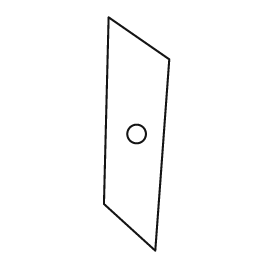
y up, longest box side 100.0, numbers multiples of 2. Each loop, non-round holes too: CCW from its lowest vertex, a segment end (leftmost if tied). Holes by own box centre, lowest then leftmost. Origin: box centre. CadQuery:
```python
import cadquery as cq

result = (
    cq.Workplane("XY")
    .moveTo(8.0, -50.0)
    .lineTo(14.0, 32.0)
    .lineTo(-12.0, 50.0)
    .lineTo(-14.0, -30.0)
    .close()
    .moveTo(0.0, 0.0)
    .circle(4.0)
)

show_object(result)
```